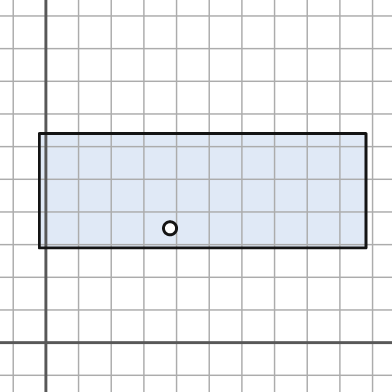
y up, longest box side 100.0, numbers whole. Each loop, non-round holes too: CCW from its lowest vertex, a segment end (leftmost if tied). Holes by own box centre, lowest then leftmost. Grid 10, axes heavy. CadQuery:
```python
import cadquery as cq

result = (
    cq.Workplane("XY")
    .moveTo(-2.0, 29.0)
    .lineTo(98.0, 29.0)
    .lineTo(98.0, 64.0)
    .lineTo(-2.0, 64.0)
    .close()
    .moveTo(38.0, 35.0)
    .circle(2.0)
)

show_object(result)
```